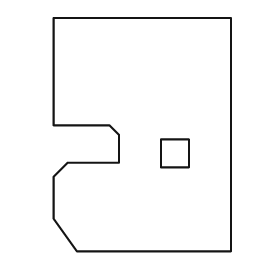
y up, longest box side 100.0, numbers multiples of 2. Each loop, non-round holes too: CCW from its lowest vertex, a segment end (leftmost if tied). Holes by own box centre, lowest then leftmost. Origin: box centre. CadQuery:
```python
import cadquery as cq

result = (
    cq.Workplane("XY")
    .moveTo(-28.0, -50.0)
    .lineTo(38.0, -50.0)
    .lineTo(38.0, 50.0)
    .lineTo(-38.0, 50.0)
    .lineTo(-38.0, 4.0)
    .lineTo(-14.0, 4.0)
    .lineTo(-10.0, 0.0)
    .lineTo(-10.0, -12.0)
    .lineTo(-32.0, -12.0)
    .lineTo(-38.0, -18.0)
    .lineTo(-38.0, -36.0)
    .close()
    .moveTo(8.0, -14.0)
    .lineTo(20.0, -14.0)
    .lineTo(20.0, -2.0)
    .lineTo(8.0, -2.0)
    .close()
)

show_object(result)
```